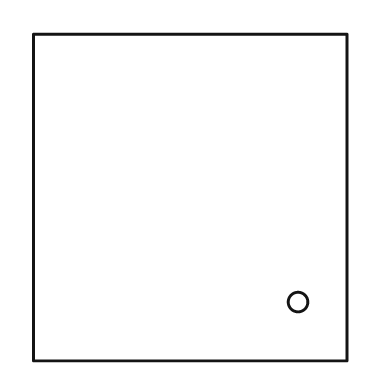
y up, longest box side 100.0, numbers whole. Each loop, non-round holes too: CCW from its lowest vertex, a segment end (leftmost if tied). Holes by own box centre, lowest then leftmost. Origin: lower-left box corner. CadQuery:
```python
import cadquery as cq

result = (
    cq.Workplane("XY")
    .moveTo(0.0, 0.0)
    .lineTo(96.0, 0.0)
    .lineTo(96.0, 100.0)
    .lineTo(0.0, 100.0)
    .close()
    .moveTo(81.0, 18.0)
    .circle(3.0)
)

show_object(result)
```